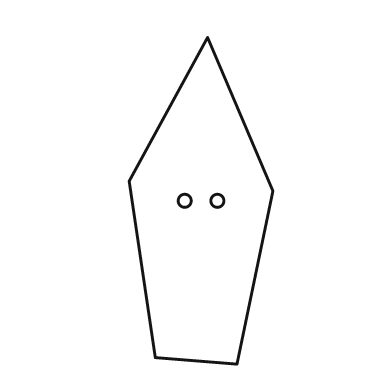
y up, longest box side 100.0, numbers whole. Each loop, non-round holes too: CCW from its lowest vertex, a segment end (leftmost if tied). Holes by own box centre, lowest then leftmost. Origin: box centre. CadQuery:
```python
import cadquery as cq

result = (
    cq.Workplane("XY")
    .moveTo(11.0, -50.0)
    .lineTo(22.0, 3.0)
    .lineTo(2.0, 50.0)
    .lineTo(-22.0, 6.0)
    .lineTo(-14.0, -48.0)
    .close()
    .moveTo(-5.0, 0.0)
    .circle(2.0)
    .moveTo(5.0, 0.0)
    .circle(2.0)
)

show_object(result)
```